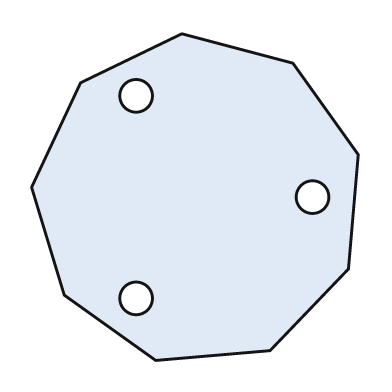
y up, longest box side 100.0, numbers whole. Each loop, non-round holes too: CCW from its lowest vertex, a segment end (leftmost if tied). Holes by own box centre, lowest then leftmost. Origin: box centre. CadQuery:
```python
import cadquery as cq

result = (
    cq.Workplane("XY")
    .moveTo(-12.0, -50.0)
    .lineTo(23.0, -47.0)
    .lineTo(47.0, -22.0)
    .lineTo(50.0, 13.0)
    .lineTo(30.0, 41.0)
    .lineTo(-4.0, 50.0)
    .lineTo(-35.0, 35.0)
    .lineTo(-50.0, 3.0)
    .lineTo(-40.0, -30.0)
    .close()
    .moveTo(-18.0, -31.0)
    .circle(5.0)
    .moveTo(36.0, 0.0)
    .circle(5.0)
    .moveTo(-18.0, 31.0)
    .circle(5.0)
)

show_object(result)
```